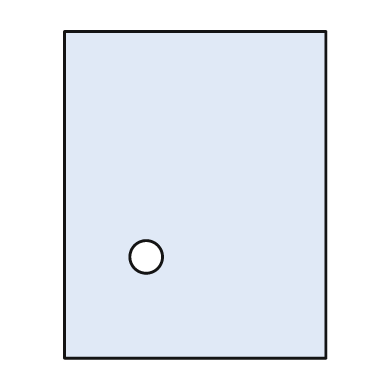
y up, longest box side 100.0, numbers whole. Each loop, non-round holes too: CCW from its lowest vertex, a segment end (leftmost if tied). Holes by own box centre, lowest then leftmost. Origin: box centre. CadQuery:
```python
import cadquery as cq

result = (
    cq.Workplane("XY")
    .moveTo(-40.0, -50.0)
    .lineTo(40.0, -50.0)
    .lineTo(40.0, 50.0)
    .lineTo(-40.0, 50.0)
    .close()
    .moveTo(-15.0, -19.0)
    .circle(5.0)
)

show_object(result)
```